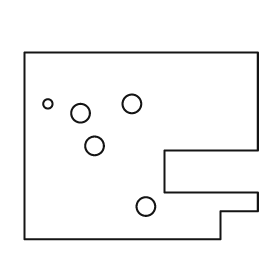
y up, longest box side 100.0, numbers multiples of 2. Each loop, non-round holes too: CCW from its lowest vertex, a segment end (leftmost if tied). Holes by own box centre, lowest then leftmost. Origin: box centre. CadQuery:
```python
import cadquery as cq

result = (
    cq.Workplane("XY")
    .moveTo(-50.0, -40.0)
    .lineTo(34.0, -40.0)
    .lineTo(34.0, -28.0)
    .lineTo(50.0, -28.0)
    .lineTo(50.0, -20.0)
    .lineTo(10.0, -20.0)
    .lineTo(10.0, -2.0)
    .lineTo(50.0, -2.0)
    .lineTo(50.0, 40.0)
    .lineTo(-50.0, 40.0)
    .close()
    .moveTo(2.0, -26.0)
    .circle(4.0)
    .moveTo(-20.0, 0.0)
    .circle(4.0)
    .moveTo(-26.0, 14.0)
    .circle(4.0)
    .moveTo(-40.0, 18.0)
    .circle(2.0)
    .moveTo(-4.0, 18.0)
    .circle(4.0)
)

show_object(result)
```